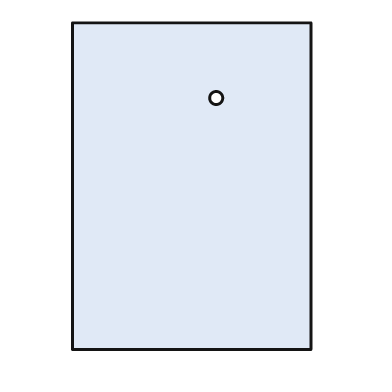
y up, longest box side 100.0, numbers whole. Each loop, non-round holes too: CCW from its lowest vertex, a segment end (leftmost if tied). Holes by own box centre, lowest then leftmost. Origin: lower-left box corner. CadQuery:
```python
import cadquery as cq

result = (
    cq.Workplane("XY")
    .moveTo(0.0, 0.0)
    .lineTo(73.0, 0.0)
    .lineTo(73.0, 100.0)
    .lineTo(0.0, 100.0)
    .close()
    .moveTo(44.0, 77.0)
    .circle(2.0)
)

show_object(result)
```